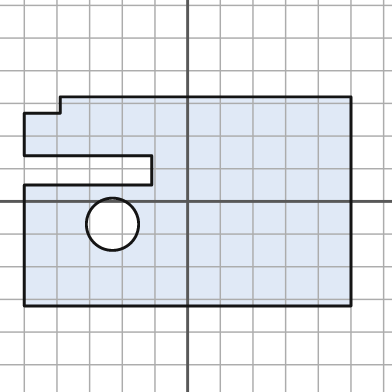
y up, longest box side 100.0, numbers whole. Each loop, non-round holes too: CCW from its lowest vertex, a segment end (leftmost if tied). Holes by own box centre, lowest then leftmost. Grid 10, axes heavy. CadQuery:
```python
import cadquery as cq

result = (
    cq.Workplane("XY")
    .moveTo(-50.0, -32.0)
    .lineTo(50.0, -32.0)
    .lineTo(50.0, 32.0)
    .lineTo(-39.0, 32.0)
    .lineTo(-39.0, 27.0)
    .lineTo(-50.0, 27.0)
    .lineTo(-50.0, 14.0)
    .lineTo(-11.0, 14.0)
    .lineTo(-11.0, 5.0)
    .lineTo(-50.0, 5.0)
    .close()
    .moveTo(-23.0, -7.0)
    .circle(8.0)
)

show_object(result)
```